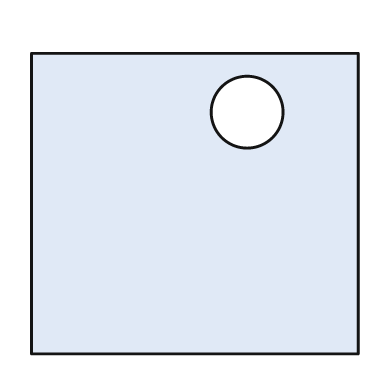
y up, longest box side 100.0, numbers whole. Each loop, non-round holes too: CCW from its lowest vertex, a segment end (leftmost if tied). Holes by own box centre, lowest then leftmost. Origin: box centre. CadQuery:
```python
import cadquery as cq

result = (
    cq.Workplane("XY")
    .moveTo(-50.0, -46.0)
    .lineTo(50.0, -46.0)
    .lineTo(50.0, 46.0)
    .lineTo(-50.0, 46.0)
    .close()
    .moveTo(16.0, 28.0)
    .circle(11.0)
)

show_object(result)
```